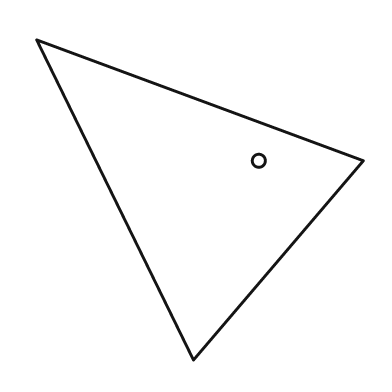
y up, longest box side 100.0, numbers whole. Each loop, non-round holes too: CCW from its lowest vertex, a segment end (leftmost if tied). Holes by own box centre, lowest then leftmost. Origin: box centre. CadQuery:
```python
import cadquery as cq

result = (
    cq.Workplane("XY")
    .moveTo(-2.0, -49.0)
    .lineTo(50.0, 12.0)
    .lineTo(-50.0, 49.0)
    .close()
    .moveTo(18.0, 12.0)
    .circle(2.0)
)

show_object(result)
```